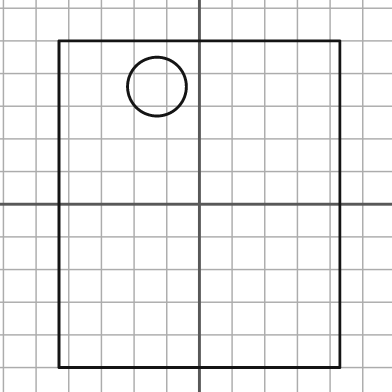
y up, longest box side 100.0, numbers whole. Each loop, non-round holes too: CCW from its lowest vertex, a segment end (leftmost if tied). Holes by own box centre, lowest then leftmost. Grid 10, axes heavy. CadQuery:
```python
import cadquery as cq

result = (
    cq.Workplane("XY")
    .moveTo(-43.0, -50.0)
    .lineTo(43.0, -50.0)
    .lineTo(43.0, 50.0)
    .lineTo(-43.0, 50.0)
    .close()
    .moveTo(-13.0, 36.0)
    .circle(9.0)
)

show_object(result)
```